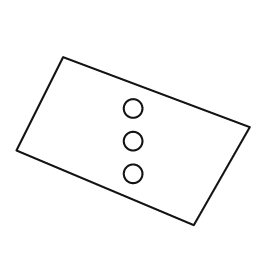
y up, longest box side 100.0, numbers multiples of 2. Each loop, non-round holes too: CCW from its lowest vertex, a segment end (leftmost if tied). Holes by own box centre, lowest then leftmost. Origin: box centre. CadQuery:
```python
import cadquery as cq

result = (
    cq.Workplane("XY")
    .moveTo(26.0, -36.0)
    .lineTo(50.0, 6.0)
    .lineTo(-30.0, 36.0)
    .lineTo(-50.0, -4.0)
    .close()
    .moveTo(0.0, -14.0)
    .circle(4.0)
    .moveTo(0.0, 0.0)
    .circle(4.0)
    .moveTo(0.0, 14.0)
    .circle(4.0)
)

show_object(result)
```